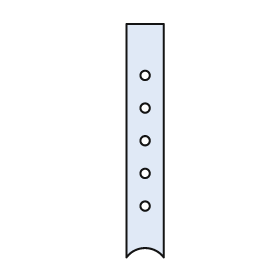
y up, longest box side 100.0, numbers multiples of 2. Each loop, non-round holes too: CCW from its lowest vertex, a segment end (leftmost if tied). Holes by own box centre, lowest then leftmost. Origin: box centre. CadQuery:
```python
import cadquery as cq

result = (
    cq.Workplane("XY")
    .moveTo(-8.0, -50.0)
    .threePointArc((0.0, -46.0), (8.0, -50.0))
    .lineTo(8.0, 50.0)
    .lineTo(-8.0, 50.0)
    .close()
    .moveTo(0.0, -28.0)
    .circle(2.0)
    .moveTo(0.0, -14.0)
    .circle(2.0)
    .moveTo(0.0, 0.0)
    .circle(2.0)
    .moveTo(0.0, 14.0)
    .circle(2.0)
    .moveTo(0.0, 28.0)
    .circle(2.0)
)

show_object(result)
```